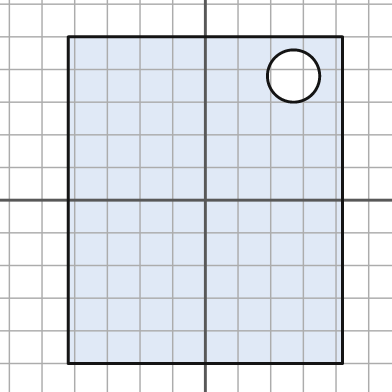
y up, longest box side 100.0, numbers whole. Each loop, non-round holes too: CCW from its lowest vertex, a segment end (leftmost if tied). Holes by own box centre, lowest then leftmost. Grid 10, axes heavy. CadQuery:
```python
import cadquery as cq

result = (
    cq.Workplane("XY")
    .moveTo(-42.0, -50.0)
    .lineTo(42.0, -50.0)
    .lineTo(42.0, 50.0)
    .lineTo(-42.0, 50.0)
    .close()
    .moveTo(27.0, 38.0)
    .circle(8.0)
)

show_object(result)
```